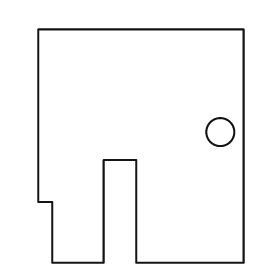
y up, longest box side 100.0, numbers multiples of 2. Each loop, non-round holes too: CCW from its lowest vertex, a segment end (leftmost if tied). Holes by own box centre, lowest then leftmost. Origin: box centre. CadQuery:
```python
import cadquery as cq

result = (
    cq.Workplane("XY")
    .moveTo(-38.0, -50.0)
    .lineTo(-16.0, -50.0)
    .lineTo(-16.0, -6.0)
    .lineTo(-2.0, -6.0)
    .lineTo(-2.0, -50.0)
    .lineTo(44.0, -50.0)
    .lineTo(44.0, 50.0)
    .lineTo(-44.0, 50.0)
    .lineTo(-44.0, -24.0)
    .lineTo(-38.0, -24.0)
    .close()
    .moveTo(34.0, 6.0)
    .circle(6.0)
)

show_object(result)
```